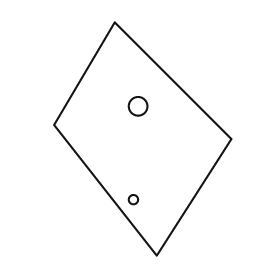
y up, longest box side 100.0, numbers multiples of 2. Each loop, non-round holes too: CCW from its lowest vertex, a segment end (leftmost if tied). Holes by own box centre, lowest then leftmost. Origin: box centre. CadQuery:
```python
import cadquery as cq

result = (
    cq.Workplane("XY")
    .moveTo(6.0, -50.0)
    .lineTo(38.0, 0.0)
    .lineTo(-12.0, 50.0)
    .lineTo(-38.0, 6.0)
    .close()
    .moveTo(-4.0, -26.0)
    .circle(2.0)
    .moveTo(-2.0, 14.0)
    .circle(4.0)
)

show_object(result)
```